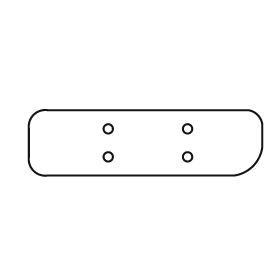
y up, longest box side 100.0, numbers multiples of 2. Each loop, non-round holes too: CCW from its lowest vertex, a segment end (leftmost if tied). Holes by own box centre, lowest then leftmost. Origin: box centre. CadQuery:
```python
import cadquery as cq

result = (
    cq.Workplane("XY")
    .moveTo(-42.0, -14.0)
    .lineTo(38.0, -14.0)
    .threePointArc((46.0, -10.0), (50.0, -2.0))
    .lineTo(50.0, 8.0)
    .threePointArc((48.0, 12.0), (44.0, 14.0))
    .lineTo(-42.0, 14.0)
    .threePointArc((-48.0, 12.0), (-50.0, 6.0))
    .lineTo(-50.0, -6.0)
    .threePointArc((-48.0, -12.0), (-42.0, -14.0))
    .close()
    .moveTo(-16.0, -6.0)
    .circle(2.0)
    .moveTo(18.0, -6.0)
    .circle(2.0)
    .moveTo(-16.0, 6.0)
    .circle(2.0)
    .moveTo(18.0, 6.0)
    .circle(2.0)
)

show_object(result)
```